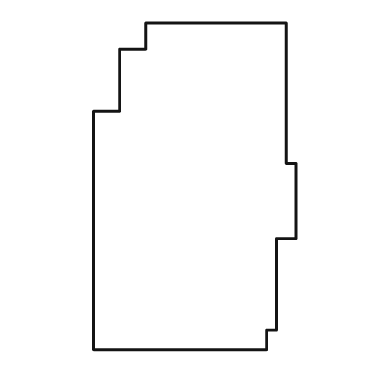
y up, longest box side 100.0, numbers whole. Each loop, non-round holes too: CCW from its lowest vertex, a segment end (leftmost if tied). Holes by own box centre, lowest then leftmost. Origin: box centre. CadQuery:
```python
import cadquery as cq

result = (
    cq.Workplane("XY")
    .moveTo(-31.0, -50.0)
    .lineTo(22.0, -50.0)
    .lineTo(22.0, -44.0)
    .lineTo(25.0, -44.0)
    .lineTo(25.0, -16.0)
    .lineTo(31.0, -16.0)
    .lineTo(31.0, 7.0)
    .lineTo(28.0, 7.0)
    .lineTo(28.0, 50.0)
    .lineTo(-15.0, 50.0)
    .lineTo(-15.0, 42.0)
    .lineTo(-23.0, 42.0)
    .lineTo(-23.0, 23.0)
    .lineTo(-31.0, 23.0)
    .close()
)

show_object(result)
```